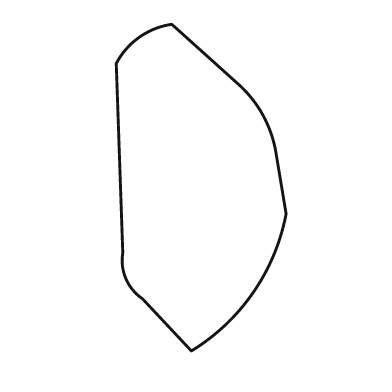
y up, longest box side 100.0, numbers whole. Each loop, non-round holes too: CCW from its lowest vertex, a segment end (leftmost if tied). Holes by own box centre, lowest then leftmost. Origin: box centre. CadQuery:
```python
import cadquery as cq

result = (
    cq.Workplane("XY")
    .moveTo(-3.0, -50.0)
    .threePointArc((16.0, -32.0), (26.0, -8.0))
    .lineTo(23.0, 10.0)
    .threePointArc((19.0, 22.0), (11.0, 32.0))
    .lineTo(-9.0, 50.0)
    .threePointArc((-19.0, 46.0), (-26.0, 38.0))
    .lineTo(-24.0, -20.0)
    .threePointArc((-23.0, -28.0), (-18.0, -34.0))
    .close()
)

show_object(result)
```